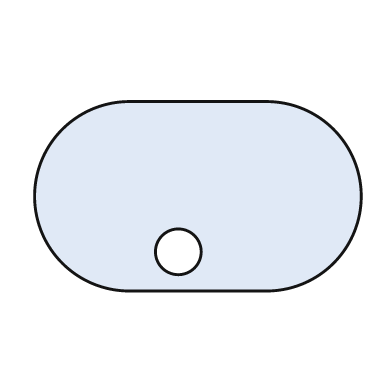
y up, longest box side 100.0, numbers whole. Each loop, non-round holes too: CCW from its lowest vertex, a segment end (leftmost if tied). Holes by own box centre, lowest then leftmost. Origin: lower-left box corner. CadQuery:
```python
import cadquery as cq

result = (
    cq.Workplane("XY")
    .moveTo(29.0, 0.0)
    .lineTo(71.0, 0.0)
    .threePointArc((100.0, 29.0), (71.0, 58.0))
    .lineTo(29.0, 58.0)
    .threePointArc((0.0, 29.0), (29.0, 0.0))
    .close()
    .moveTo(44.0, 12.0)
    .circle(7.0)
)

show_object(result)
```